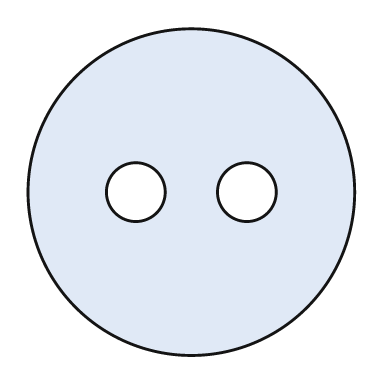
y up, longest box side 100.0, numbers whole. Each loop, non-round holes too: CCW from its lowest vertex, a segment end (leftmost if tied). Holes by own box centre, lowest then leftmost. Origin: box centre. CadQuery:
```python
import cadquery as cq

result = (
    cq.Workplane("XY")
    .moveTo(0.0, 0.0)
    .circle(50.0)
    .moveTo(-17.0, 0.0)
    .circle(9.0)
    .moveTo(17.0, 0.0)
    .circle(9.0)
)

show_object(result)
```